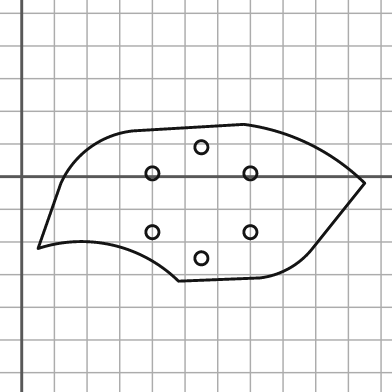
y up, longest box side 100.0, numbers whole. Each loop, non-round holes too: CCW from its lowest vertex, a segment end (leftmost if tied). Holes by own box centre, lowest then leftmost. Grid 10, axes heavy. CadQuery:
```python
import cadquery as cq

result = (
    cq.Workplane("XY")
    .moveTo(48.0, -32.0)
    .lineTo(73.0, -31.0)
    .threePointArc((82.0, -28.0), (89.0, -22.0))
    .lineTo(105.0, -2.0)
    .threePointArc((88.0, 10.0), (68.0, 16.0))
    .lineTo(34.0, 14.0)
    .threePointArc((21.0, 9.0), (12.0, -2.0))
    .lineTo(5.0, -22.0)
    .threePointArc((28.0, -21.0), (48.0, -32.0))
    .close()
    .moveTo(55.0, -25.0)
    .circle(2.0)
    .moveTo(40.0, -17.0)
    .circle(2.0)
    .moveTo(70.0, -17.0)
    .circle(2.0)
    .moveTo(40.0, 1.0)
    .circle(2.0)
    .moveTo(70.0, 1.0)
    .circle(2.0)
    .moveTo(55.0, 9.0)
    .circle(2.0)
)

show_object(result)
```